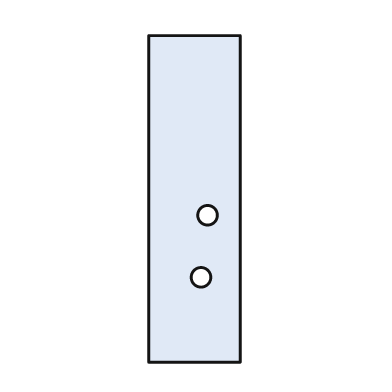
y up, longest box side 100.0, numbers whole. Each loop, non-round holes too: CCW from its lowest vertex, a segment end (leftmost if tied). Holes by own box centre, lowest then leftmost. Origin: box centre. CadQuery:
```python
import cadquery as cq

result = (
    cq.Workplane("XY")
    .moveTo(-14.0, -50.0)
    .lineTo(14.0, -50.0)
    .lineTo(14.0, 50.0)
    .lineTo(-14.0, 50.0)
    .close()
    .moveTo(2.0, -24.0)
    .circle(3.0)
    .moveTo(4.0, -5.0)
    .circle(3.0)
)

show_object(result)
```